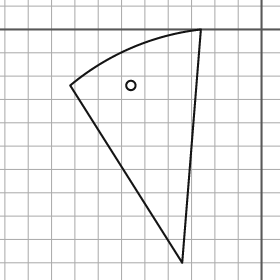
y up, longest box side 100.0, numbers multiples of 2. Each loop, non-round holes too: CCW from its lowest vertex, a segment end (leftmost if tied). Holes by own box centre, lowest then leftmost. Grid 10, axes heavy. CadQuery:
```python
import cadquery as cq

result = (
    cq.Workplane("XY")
    .moveTo(-34.0, -100.0)
    .lineTo(-26.0, 0.0)
    .threePointArc((-56.0, -8.0), (-82.0, -24.0))
    .close()
    .moveTo(-56.0, -24.0)
    .circle(2.0)
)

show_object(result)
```